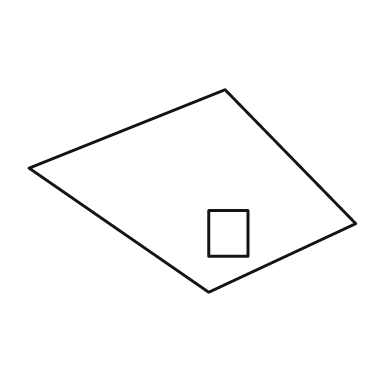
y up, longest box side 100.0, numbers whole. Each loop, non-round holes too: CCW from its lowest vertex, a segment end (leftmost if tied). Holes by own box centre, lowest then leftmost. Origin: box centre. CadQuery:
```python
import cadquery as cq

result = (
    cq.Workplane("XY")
    .moveTo(5.0, -31.0)
    .lineTo(50.0, -10.0)
    .lineTo(10.0, 31.0)
    .lineTo(-50.0, 7.0)
    .close()
    .moveTo(5.0, -20.0)
    .lineTo(17.0, -20.0)
    .lineTo(17.0, -6.0)
    .lineTo(5.0, -6.0)
    .close()
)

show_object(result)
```